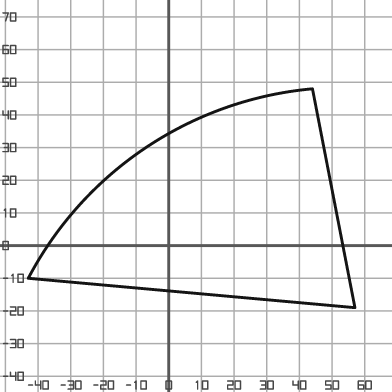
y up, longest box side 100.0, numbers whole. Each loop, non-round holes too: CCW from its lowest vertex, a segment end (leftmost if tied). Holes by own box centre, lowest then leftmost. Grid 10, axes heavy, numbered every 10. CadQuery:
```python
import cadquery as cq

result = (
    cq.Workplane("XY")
    .moveTo(57.0, -19.0)
    .lineTo(44.0, 48.0)
    .threePointArc((-7.0, 30.0), (-43.0, -10.0))
    .close()
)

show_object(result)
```